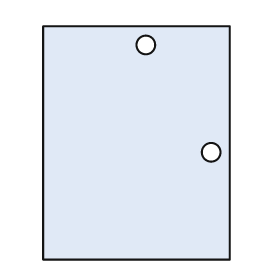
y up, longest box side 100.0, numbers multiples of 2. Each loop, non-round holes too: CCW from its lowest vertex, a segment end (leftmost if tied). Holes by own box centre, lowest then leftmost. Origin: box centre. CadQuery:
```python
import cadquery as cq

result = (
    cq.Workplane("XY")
    .moveTo(-40.0, -50.0)
    .lineTo(40.0, -50.0)
    .lineTo(40.0, 50.0)
    .lineTo(-40.0, 50.0)
    .close()
    .moveTo(32.0, -4.0)
    .circle(4.0)
    .moveTo(4.0, 42.0)
    .circle(4.0)
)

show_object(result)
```